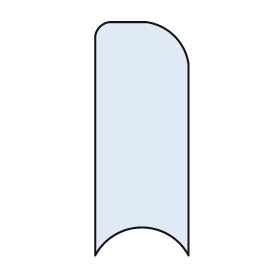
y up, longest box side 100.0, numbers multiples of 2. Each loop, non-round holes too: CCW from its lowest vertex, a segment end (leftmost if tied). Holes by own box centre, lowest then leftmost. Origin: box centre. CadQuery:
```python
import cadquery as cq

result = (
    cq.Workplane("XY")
    .moveTo(-20.0, -50.0)
    .threePointArc((0.0, -38.0), (20.0, -50.0))
    .lineTo(20.0, 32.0)
    .threePointArc((14.0, 44.0), (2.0, 50.0))
    .lineTo(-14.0, 50.0)
    .threePointArc((-18.0, 48.0), (-20.0, 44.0))
    .close()
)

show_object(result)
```